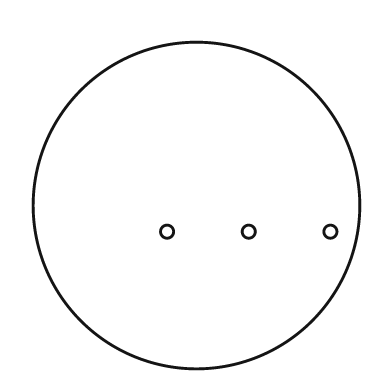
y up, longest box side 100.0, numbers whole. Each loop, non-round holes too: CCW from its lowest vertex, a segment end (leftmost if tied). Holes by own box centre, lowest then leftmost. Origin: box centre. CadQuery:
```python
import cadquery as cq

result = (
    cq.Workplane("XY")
    .moveTo(0.0, 0.0)
    .circle(50.0)
    .moveTo(-9.0, -8.0)
    .circle(2.0)
    .moveTo(16.0, -8.0)
    .circle(2.0)
    .moveTo(41.0, -8.0)
    .circle(2.0)
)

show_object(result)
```